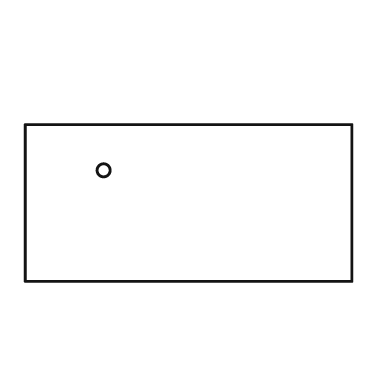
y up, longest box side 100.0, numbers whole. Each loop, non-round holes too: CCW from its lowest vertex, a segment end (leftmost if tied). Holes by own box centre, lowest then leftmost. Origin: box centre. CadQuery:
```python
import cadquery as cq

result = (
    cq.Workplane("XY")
    .moveTo(-50.0, -24.0)
    .lineTo(50.0, -24.0)
    .lineTo(50.0, 24.0)
    .lineTo(-50.0, 24.0)
    .close()
    .moveTo(-26.0, 10.0)
    .circle(2.0)
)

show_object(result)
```